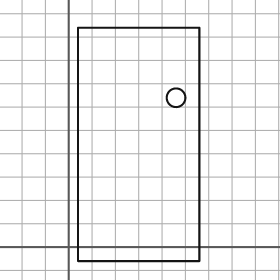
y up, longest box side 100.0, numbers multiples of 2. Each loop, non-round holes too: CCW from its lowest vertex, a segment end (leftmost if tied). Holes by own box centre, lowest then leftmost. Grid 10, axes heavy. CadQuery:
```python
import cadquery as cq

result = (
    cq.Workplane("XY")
    .moveTo(4.0, -6.0)
    .lineTo(56.0, -6.0)
    .lineTo(56.0, 94.0)
    .lineTo(4.0, 94.0)
    .close()
    .moveTo(46.0, 64.0)
    .circle(4.0)
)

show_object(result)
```